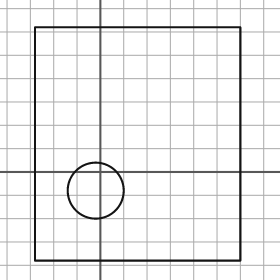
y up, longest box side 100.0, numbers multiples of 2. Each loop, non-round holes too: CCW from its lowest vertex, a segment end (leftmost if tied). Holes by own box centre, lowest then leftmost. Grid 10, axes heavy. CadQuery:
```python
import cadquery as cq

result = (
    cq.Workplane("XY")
    .moveTo(-28.0, -38.0)
    .lineTo(60.0, -38.0)
    .lineTo(60.0, 62.0)
    .lineTo(-28.0, 62.0)
    .close()
    .moveTo(-2.0, -8.0)
    .circle(12.0)
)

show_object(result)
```